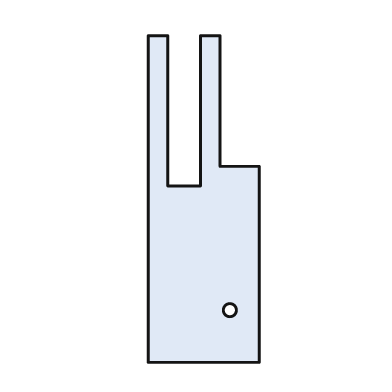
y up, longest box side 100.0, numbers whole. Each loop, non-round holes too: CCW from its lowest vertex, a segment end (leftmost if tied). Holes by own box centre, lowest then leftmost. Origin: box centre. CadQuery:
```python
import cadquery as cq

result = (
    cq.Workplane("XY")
    .moveTo(-17.0, -50.0)
    .lineTo(17.0, -50.0)
    .lineTo(17.0, 10.0)
    .lineTo(5.0, 10.0)
    .lineTo(5.0, 50.0)
    .lineTo(-1.0, 50.0)
    .lineTo(-1.0, 4.0)
    .lineTo(-11.0, 4.0)
    .lineTo(-11.0, 50.0)
    .lineTo(-17.0, 50.0)
    .close()
    .moveTo(8.0, -34.0)
    .circle(2.0)
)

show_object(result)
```